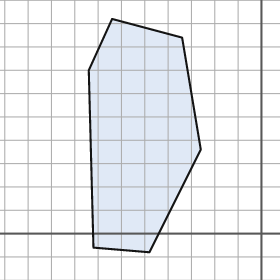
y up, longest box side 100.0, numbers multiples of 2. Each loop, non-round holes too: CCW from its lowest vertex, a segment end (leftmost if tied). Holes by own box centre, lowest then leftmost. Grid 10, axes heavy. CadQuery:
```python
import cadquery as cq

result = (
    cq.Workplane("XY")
    .moveTo(-48.0, -8.0)
    .lineTo(-26.0, 36.0)
    .lineTo(-34.0, 84.0)
    .lineTo(-64.0, 92.0)
    .lineTo(-74.0, 70.0)
    .lineTo(-72.0, -6.0)
    .close()
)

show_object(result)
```